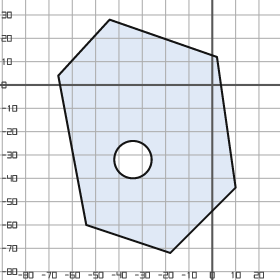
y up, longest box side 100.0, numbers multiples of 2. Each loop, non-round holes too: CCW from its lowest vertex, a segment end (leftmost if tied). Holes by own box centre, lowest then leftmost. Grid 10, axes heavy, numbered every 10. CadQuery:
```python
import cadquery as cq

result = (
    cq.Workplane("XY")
    .moveTo(-18.0, -72.0)
    .lineTo(10.0, -44.0)
    .lineTo(2.0, 12.0)
    .lineTo(-44.0, 28.0)
    .lineTo(-66.0, 4.0)
    .lineTo(-54.0, -60.0)
    .close()
    .moveTo(-34.0, -32.0)
    .circle(8.0)
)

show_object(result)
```